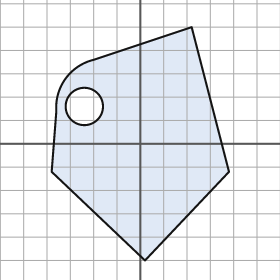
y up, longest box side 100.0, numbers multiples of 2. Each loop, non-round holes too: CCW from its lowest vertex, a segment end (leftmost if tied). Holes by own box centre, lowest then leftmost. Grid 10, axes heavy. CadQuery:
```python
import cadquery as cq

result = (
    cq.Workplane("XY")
    .moveTo(2.0, -50.0)
    .lineTo(38.0, -12.0)
    .lineTo(22.0, 50.0)
    .lineTo(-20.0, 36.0)
    .threePointArc((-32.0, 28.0), (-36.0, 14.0))
    .lineTo(-38.0, -12.0)
    .close()
    .moveTo(-24.0, 16.0)
    .circle(8.0)
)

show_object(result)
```